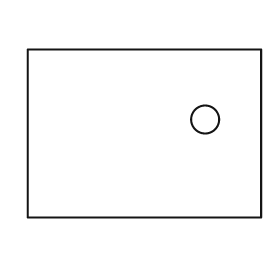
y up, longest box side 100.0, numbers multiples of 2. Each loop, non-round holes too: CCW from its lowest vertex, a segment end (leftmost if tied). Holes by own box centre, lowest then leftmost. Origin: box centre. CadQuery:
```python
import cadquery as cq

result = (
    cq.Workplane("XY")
    .moveTo(-50.0, -36.0)
    .lineTo(50.0, -36.0)
    .lineTo(50.0, 36.0)
    .lineTo(-50.0, 36.0)
    .close()
    .moveTo(26.0, 6.0)
    .circle(6.0)
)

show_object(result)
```